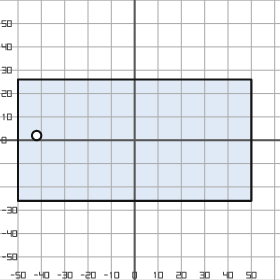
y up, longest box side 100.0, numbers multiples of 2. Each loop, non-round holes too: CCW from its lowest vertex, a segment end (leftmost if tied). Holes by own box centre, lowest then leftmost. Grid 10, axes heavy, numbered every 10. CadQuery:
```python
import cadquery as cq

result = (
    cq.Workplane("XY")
    .moveTo(-50.0, -26.0)
    .lineTo(50.0, -26.0)
    .lineTo(50.0, 26.0)
    .lineTo(-50.0, 26.0)
    .close()
    .moveTo(-42.0, 2.0)
    .circle(2.0)
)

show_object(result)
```